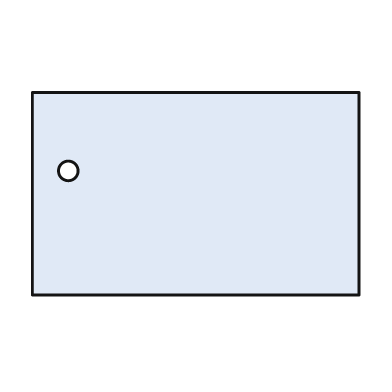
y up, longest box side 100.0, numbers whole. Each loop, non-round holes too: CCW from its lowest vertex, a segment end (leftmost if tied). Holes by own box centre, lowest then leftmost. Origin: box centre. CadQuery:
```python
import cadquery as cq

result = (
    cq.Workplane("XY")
    .moveTo(-50.0, -31.0)
    .lineTo(50.0, -31.0)
    .lineTo(50.0, 31.0)
    .lineTo(-50.0, 31.0)
    .close()
    .moveTo(-39.0, 7.0)
    .circle(3.0)
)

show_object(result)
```